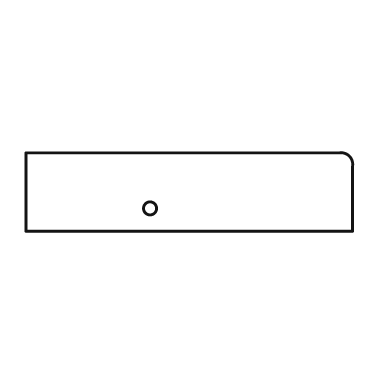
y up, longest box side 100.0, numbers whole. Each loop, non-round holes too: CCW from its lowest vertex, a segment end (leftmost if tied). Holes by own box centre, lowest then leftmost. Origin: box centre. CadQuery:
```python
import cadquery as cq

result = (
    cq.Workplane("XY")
    .moveTo(-50.0, -12.0)
    .lineTo(50.0, -12.0)
    .lineTo(50.0, 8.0)
    .threePointArc((49.0, 11.0), (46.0, 12.0))
    .lineTo(-50.0, 12.0)
    .close()
    .moveTo(-12.0, -5.0)
    .circle(2.0)
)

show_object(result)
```